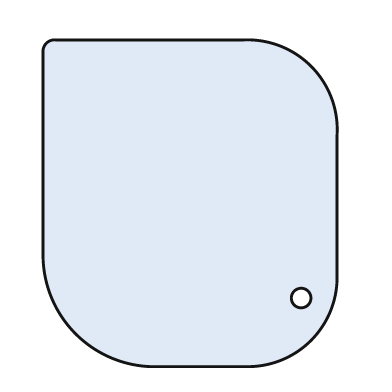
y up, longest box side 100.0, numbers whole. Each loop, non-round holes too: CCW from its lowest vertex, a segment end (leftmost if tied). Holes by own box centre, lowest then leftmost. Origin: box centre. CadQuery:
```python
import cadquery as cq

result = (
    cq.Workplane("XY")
    .moveTo(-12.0, -50.0)
    .lineTo(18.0, -50.0)
    .threePointArc((37.0, -42.0), (45.0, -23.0))
    .lineTo(45.0, 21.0)
    .threePointArc((37.0, 42.0), (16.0, 50.0))
    .lineTo(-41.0, 50.0)
    .threePointArc((-44.0, 49.0), (-45.0, 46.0))
    .lineTo(-45.0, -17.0)
    .threePointArc((-35.0, -40.0), (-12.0, -50.0))
    .close()
    .moveTo(34.0, -29.0)
    .circle(3.0)
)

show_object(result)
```